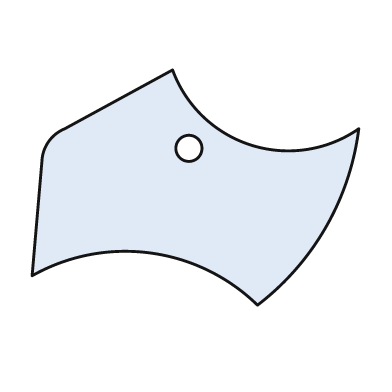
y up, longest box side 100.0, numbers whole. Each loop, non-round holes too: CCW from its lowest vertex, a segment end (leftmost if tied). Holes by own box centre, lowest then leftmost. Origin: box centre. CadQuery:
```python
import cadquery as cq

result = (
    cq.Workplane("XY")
    .moveTo(19.0, -36.0)
    .threePointArc((40.0, -12.0), (50.0, 18.0))
    .threePointArc((17.0, 13.0), (-7.0, 36.0))
    .lineTo(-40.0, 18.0)
    .threePointArc((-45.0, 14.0), (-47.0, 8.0))
    .lineTo(-50.0, -27.0)
    .threePointArc((-14.0, -20.0), (19.0, -36.0))
    .close()
    .moveTo(-2.0, 12.0)
    .circle(4.0)
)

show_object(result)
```